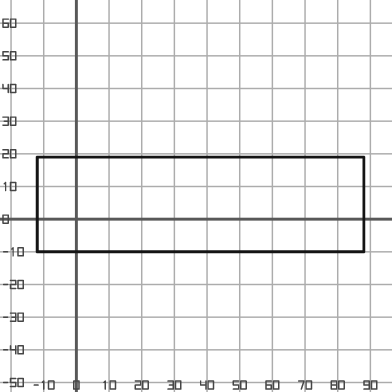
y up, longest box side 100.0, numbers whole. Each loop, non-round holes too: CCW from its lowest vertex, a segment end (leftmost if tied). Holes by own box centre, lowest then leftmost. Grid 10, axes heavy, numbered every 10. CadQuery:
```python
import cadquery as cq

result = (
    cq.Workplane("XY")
    .moveTo(-12.0, -10.0)
    .lineTo(88.0, -10.0)
    .lineTo(88.0, 19.0)
    .lineTo(-12.0, 19.0)
    .close()
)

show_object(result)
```